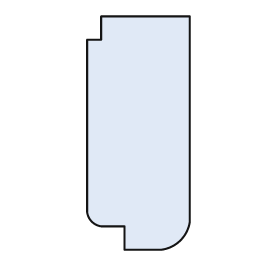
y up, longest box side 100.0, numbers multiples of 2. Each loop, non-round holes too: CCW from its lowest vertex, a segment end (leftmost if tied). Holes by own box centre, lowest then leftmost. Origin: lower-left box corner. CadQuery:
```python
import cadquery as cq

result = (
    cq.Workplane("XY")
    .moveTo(16.0, 0.0)
    .lineTo(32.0, 0.0)
    .threePointArc((40.0, 4.0), (44.0, 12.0))
    .lineTo(44.0, 100.0)
    .lineTo(6.0, 100.0)
    .lineTo(6.0, 90.0)
    .lineTo(0.0, 90.0)
    .lineTo(0.0, 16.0)
    .threePointArc((2.0, 12.0), (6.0, 10.0))
    .lineTo(16.0, 10.0)
    .close()
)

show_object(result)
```